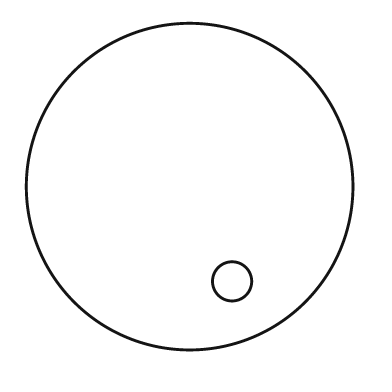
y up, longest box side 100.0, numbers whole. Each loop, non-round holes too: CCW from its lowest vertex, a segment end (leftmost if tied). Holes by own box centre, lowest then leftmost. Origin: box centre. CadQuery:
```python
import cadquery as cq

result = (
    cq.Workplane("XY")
    .moveTo(0.0, 0.0)
    .circle(50.0)
    .moveTo(13.0, -29.0)
    .circle(6.0)
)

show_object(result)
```